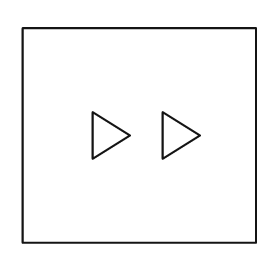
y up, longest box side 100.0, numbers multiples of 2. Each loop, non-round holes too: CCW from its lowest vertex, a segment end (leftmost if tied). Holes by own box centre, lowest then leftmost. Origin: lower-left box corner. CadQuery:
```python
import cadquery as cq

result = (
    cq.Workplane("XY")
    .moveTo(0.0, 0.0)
    .lineTo(100.0, 0.0)
    .lineTo(100.0, 92.0)
    .lineTo(0.0, 92.0)
    .close()
    .moveTo(30.0, 36.0)
    .lineTo(46.0, 46.0)
    .lineTo(30.0, 56.0)
    .close()
    .moveTo(60.0, 36.0)
    .lineTo(76.0, 46.0)
    .lineTo(60.0, 56.0)
    .close()
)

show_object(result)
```